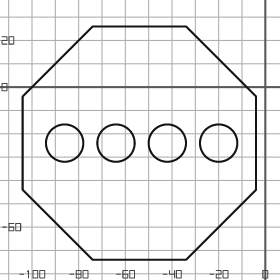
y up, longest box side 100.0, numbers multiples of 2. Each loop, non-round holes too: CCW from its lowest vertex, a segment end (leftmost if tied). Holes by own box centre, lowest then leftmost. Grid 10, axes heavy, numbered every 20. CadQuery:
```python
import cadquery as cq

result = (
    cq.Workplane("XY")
    .moveTo(-74.0, -74.0)
    .lineTo(-34.0, -74.0)
    .lineTo(-4.0, -44.0)
    .lineTo(-4.0, -4.0)
    .lineTo(-34.0, 26.0)
    .lineTo(-74.0, 26.0)
    .lineTo(-104.0, -4.0)
    .lineTo(-104.0, -44.0)
    .close()
    .moveTo(-86.0, -24.0)
    .circle(8.0)
    .moveTo(-64.0, -24.0)
    .circle(8.0)
    .moveTo(-42.0, -24.0)
    .circle(8.0)
    .moveTo(-20.0, -24.0)
    .circle(8.0)
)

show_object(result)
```